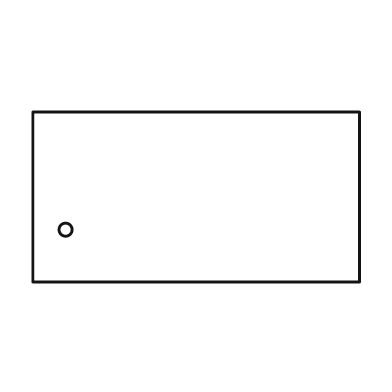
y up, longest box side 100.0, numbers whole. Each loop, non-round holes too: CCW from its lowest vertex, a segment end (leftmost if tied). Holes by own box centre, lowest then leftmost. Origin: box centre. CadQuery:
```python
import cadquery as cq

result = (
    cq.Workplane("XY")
    .moveTo(-50.0, -26.0)
    .lineTo(50.0, -26.0)
    .lineTo(50.0, 26.0)
    .lineTo(-50.0, 26.0)
    .close()
    .moveTo(-40.0, -10.0)
    .circle(2.0)
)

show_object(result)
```